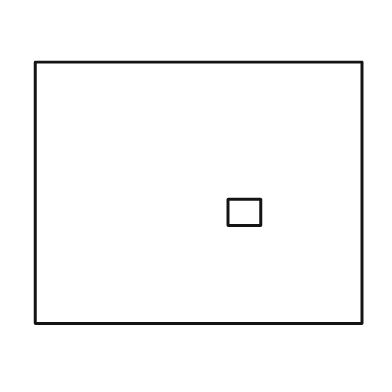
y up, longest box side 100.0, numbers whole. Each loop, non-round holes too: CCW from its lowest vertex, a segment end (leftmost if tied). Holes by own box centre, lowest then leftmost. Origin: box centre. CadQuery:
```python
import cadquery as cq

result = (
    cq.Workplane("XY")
    .moveTo(-50.0, -40.0)
    .lineTo(50.0, -40.0)
    .lineTo(50.0, 40.0)
    .lineTo(-50.0, 40.0)
    .close()
    .moveTo(9.0, -10.0)
    .lineTo(19.0, -10.0)
    .lineTo(19.0, -2.0)
    .lineTo(9.0, -2.0)
    .close()
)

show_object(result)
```